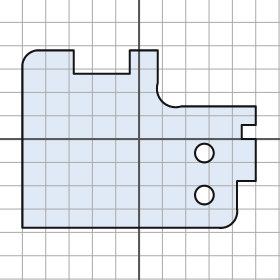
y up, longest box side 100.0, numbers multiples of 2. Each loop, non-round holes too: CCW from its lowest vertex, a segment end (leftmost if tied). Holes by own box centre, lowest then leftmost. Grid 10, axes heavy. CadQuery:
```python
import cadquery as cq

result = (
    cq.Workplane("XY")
    .moveTo(-50.0, -38.0)
    .lineTo(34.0, -38.0)
    .threePointArc((40.0, -36.0), (42.0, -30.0))
    .lineTo(42.0, -18.0)
    .lineTo(50.0, -18.0)
    .lineTo(50.0, 0.0)
    .lineTo(44.0, 0.0)
    .lineTo(44.0, 6.0)
    .lineTo(50.0, 6.0)
    .lineTo(50.0, 14.0)
    .lineTo(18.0, 14.0)
    .threePointArc((10.0, 16.0), (8.0, 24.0))
    .lineTo(8.0, 38.0)
    .lineTo(-4.0, 38.0)
    .lineTo(-4.0, 28.0)
    .lineTo(-28.0, 28.0)
    .lineTo(-28.0, 38.0)
    .lineTo(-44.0, 38.0)
    .threePointArc((-48.0, 36.0), (-50.0, 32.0))
    .close()
    .moveTo(28.0, -24.0)
    .circle(4.0)
    .moveTo(28.0, -6.0)
    .circle(4.0)
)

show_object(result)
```